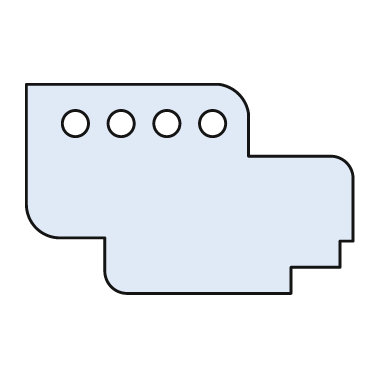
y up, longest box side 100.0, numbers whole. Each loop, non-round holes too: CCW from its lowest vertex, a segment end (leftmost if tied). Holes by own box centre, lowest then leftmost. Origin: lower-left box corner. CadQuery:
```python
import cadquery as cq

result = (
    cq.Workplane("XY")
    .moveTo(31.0, 0.0)
    .lineTo(81.0, 0.0)
    .lineTo(81.0, 8.0)
    .lineTo(96.0, 8.0)
    .lineTo(96.0, 16.0)
    .lineTo(100.0, 16.0)
    .lineTo(100.0, 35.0)
    .threePointArc((98.0, 40.0), (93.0, 42.0))
    .lineTo(68.0, 42.0)
    .lineTo(68.0, 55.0)
    .threePointArc((65.0, 61.0), (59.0, 64.0))
    .lineTo(0.0, 64.0)
    .lineTo(0.0, 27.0)
    .threePointArc((3.0, 20.0), (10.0, 17.0))
    .lineTo(24.0, 17.0)
    .lineTo(24.0, 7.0)
    .threePointArc((26.0, 2.0), (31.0, 0.0))
    .close()
    .moveTo(15.0, 52.0)
    .circle(4.0)
    .moveTo(29.0, 52.0)
    .circle(4.0)
    .moveTo(43.0, 52.0)
    .circle(4.0)
    .moveTo(57.0, 52.0)
    .circle(4.0)
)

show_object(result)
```